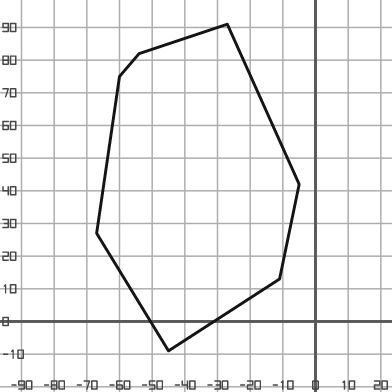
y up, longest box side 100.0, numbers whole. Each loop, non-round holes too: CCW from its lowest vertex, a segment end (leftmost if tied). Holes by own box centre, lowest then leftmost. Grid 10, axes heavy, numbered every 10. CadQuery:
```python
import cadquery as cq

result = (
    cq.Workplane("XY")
    .moveTo(-45.0, -9.0)
    .lineTo(-11.0, 13.0)
    .lineTo(-5.0, 42.0)
    .lineTo(-27.0, 91.0)
    .lineTo(-54.0, 82.0)
    .lineTo(-60.0, 75.0)
    .lineTo(-67.0, 27.0)
    .close()
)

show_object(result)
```